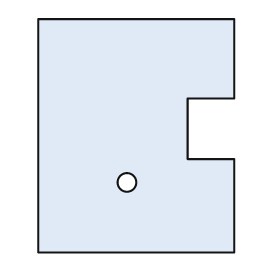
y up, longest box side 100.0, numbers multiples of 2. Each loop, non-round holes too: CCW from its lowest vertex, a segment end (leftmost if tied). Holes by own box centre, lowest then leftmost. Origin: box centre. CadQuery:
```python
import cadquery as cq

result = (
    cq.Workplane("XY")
    .moveTo(-42.0, -50.0)
    .lineTo(42.0, -50.0)
    .lineTo(42.0, -10.0)
    .lineTo(22.0, -10.0)
    .lineTo(22.0, 16.0)
    .lineTo(42.0, 16.0)
    .lineTo(42.0, 50.0)
    .lineTo(-42.0, 50.0)
    .close()
    .moveTo(-4.0, -20.0)
    .circle(4.0)
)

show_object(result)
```